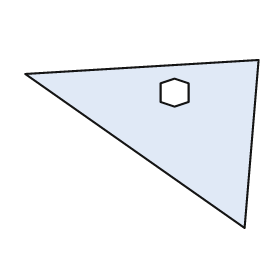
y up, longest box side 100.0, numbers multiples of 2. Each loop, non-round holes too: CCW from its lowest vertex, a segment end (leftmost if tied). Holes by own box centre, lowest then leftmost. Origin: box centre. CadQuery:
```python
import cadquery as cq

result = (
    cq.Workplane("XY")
    .moveTo(44.0, -36.0)
    .lineTo(50.0, 36.0)
    .lineTo(-50.0, 30.0)
    .close()
    .moveTo(14.0, 16.0)
    .lineTo(20.0, 18.0)
    .lineTo(20.0, 26.0)
    .lineTo(14.0, 28.0)
    .lineTo(8.0, 26.0)
    .lineTo(8.0, 18.0)
    .close()
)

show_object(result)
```